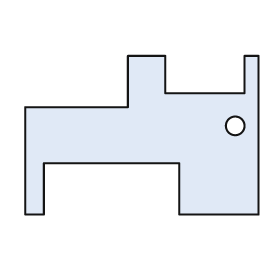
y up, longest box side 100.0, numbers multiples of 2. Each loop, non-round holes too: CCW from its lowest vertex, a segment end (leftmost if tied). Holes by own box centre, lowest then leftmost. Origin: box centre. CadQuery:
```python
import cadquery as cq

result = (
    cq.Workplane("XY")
    .moveTo(-50.0, -34.0)
    .lineTo(-42.0, -34.0)
    .lineTo(-42.0, -12.0)
    .lineTo(16.0, -12.0)
    .lineTo(16.0, -34.0)
    .lineTo(50.0, -34.0)
    .lineTo(50.0, 34.0)
    .lineTo(44.0, 34.0)
    .lineTo(44.0, 18.0)
    .lineTo(10.0, 18.0)
    .lineTo(10.0, 34.0)
    .lineTo(-6.0, 34.0)
    .lineTo(-6.0, 12.0)
    .lineTo(-50.0, 12.0)
    .close()
    .moveTo(40.0, 4.0)
    .circle(4.0)
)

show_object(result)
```